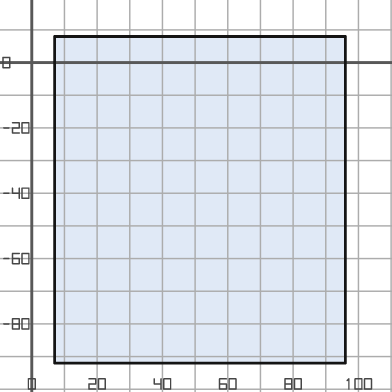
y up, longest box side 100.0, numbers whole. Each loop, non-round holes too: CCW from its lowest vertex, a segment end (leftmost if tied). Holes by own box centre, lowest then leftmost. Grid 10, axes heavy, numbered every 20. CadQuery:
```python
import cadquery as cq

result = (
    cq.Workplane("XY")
    .moveTo(7.0, -92.0)
    .lineTo(96.0, -92.0)
    .lineTo(96.0, 8.0)
    .lineTo(7.0, 8.0)
    .close()
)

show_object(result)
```